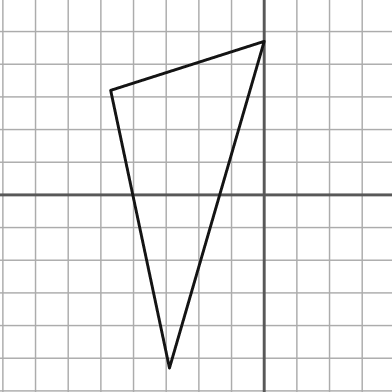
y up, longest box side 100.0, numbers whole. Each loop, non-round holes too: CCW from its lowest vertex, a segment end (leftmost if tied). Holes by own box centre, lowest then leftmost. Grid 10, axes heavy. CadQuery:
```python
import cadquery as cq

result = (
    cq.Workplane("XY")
    .moveTo(-29.0, -53.0)
    .lineTo(0.0, 47.0)
    .lineTo(-47.0, 32.0)
    .close()
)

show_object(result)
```